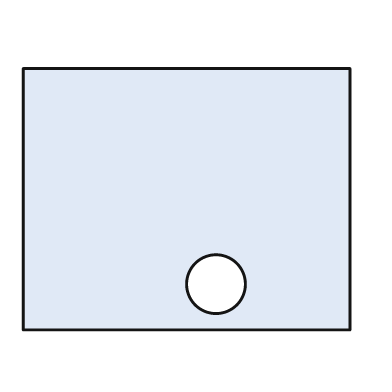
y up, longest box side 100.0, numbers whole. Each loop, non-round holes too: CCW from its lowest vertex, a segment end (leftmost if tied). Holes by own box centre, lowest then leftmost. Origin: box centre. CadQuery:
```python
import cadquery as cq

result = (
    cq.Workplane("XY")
    .moveTo(-50.0, -40.0)
    .lineTo(50.0, -40.0)
    .lineTo(50.0, 40.0)
    .lineTo(-50.0, 40.0)
    .close()
    .moveTo(9.0, -26.0)
    .circle(9.0)
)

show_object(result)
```